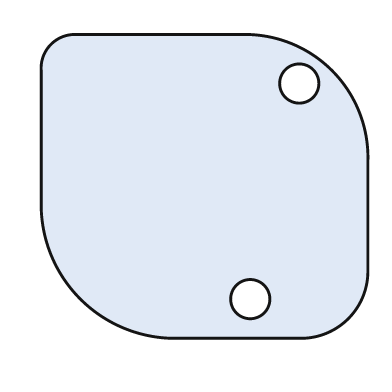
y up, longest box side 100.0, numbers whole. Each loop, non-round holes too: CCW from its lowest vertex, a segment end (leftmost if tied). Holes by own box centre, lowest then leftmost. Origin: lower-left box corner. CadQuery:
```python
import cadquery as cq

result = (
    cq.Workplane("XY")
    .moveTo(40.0, 0.0)
    .lineTo(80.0, 0.0)
    .threePointArc((94.0, 6.0), (100.0, 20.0))
    .lineTo(100.0, 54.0)
    .threePointArc((89.0, 82.0), (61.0, 93.0))
    .lineTo(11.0, 93.0)
    .threePointArc((3.0, 90.0), (0.0, 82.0))
    .lineTo(0.0, 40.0)
    .threePointArc((12.0, 12.0), (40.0, 0.0))
    .close()
    .moveTo(64.0, 12.0)
    .circle(6.0)
    .moveTo(79.0, 78.0)
    .circle(6.0)
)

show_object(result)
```